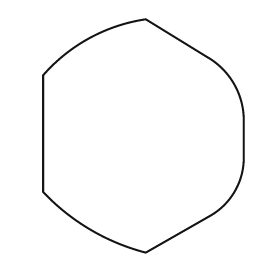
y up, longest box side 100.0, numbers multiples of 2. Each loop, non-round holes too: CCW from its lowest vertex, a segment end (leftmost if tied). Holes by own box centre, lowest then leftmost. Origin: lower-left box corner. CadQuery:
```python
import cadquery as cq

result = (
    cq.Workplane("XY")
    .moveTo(44.0, 0.0)
    .lineTo(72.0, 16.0)
    .threePointArc((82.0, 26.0), (86.0, 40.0))
    .lineTo(86.0, 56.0)
    .threePointArc((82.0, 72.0), (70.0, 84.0))
    .lineTo(44.0, 100.0)
    .threePointArc((20.0, 92.0), (0.0, 76.0))
    .lineTo(0.0, 26.0)
    .threePointArc((20.0, 10.0), (44.0, 0.0))
    .close()
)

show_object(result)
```